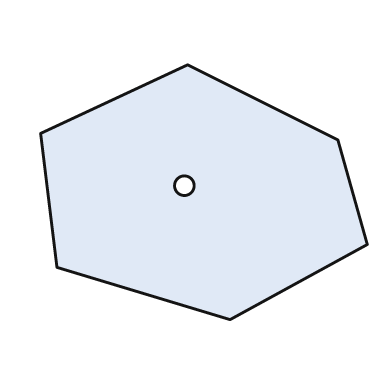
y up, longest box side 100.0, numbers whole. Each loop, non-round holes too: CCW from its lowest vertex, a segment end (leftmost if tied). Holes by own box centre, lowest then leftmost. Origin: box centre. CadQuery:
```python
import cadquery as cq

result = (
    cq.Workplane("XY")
    .moveTo(8.0, -39.0)
    .lineTo(50.0, -16.0)
    .lineTo(41.0, 16.0)
    .lineTo(-5.0, 39.0)
    .lineTo(-50.0, 18.0)
    .lineTo(-45.0, -23.0)
    .close()
    .moveTo(-6.0, 2.0)
    .circle(3.0)
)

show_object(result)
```